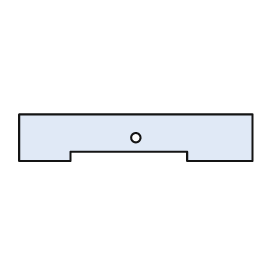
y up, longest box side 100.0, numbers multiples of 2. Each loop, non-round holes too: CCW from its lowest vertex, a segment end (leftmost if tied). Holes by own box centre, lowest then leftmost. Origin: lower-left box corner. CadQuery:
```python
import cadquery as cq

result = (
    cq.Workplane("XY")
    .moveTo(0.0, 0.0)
    .lineTo(22.0, 0.0)
    .lineTo(22.0, 4.0)
    .lineTo(72.0, 4.0)
    .lineTo(72.0, 0.0)
    .lineTo(100.0, 0.0)
    .lineTo(100.0, 20.0)
    .lineTo(0.0, 20.0)
    .close()
    .moveTo(50.0, 10.0)
    .circle(2.0)
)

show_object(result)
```